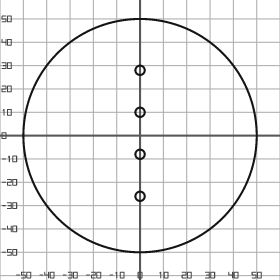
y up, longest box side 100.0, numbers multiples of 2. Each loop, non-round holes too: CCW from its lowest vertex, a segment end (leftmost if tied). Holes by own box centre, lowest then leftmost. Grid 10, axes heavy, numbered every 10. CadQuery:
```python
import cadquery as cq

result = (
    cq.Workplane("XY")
    .moveTo(0.0, 0.0)
    .circle(50.0)
    .moveTo(0.0, -26.0)
    .circle(2.0)
    .moveTo(0.0, -8.0)
    .circle(2.0)
    .moveTo(0.0, 10.0)
    .circle(2.0)
    .moveTo(0.0, 28.0)
    .circle(2.0)
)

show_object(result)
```